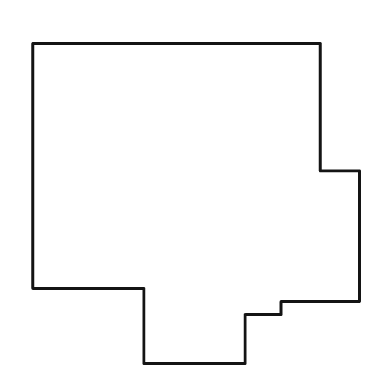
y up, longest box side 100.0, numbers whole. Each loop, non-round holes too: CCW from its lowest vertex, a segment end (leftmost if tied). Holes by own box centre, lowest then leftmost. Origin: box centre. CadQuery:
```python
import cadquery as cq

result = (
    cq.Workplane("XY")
    .moveTo(-16.0, -49.0)
    .lineTo(15.0, -49.0)
    .lineTo(15.0, -34.0)
    .lineTo(26.0, -34.0)
    .lineTo(26.0, -30.0)
    .lineTo(50.0, -30.0)
    .lineTo(50.0, 10.0)
    .lineTo(38.0, 10.0)
    .lineTo(38.0, 49.0)
    .lineTo(-50.0, 49.0)
    .lineTo(-50.0, -26.0)
    .lineTo(-16.0, -26.0)
    .close()
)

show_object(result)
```